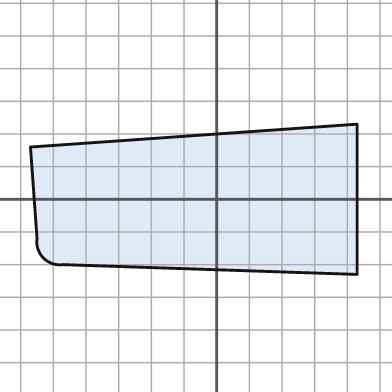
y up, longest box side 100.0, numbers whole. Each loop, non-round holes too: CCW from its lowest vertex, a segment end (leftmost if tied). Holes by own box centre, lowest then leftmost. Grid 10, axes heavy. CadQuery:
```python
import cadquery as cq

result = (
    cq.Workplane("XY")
    .moveTo(43.0, -23.0)
    .lineTo(43.0, 23.0)
    .lineTo(-57.0, 16.0)
    .lineTo(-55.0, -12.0)
    .threePointArc((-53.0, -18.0), (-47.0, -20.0))
    .close()
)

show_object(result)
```